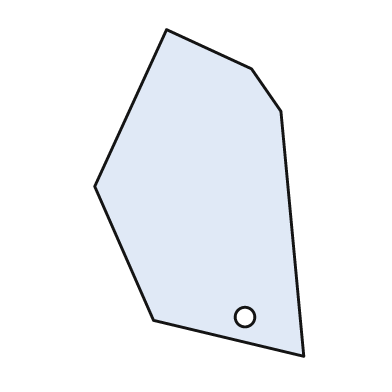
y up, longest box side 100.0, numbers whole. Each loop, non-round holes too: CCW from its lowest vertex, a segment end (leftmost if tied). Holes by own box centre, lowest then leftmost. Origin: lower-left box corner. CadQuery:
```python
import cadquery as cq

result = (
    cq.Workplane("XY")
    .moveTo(64.0, 0.0)
    .lineTo(57.0, 75.0)
    .lineTo(48.0, 88.0)
    .lineTo(22.0, 100.0)
    .lineTo(0.0, 52.0)
    .lineTo(18.0, 11.0)
    .close()
    .moveTo(46.0, 12.0)
    .circle(3.0)
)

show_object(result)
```